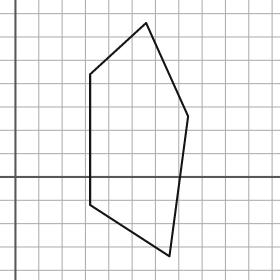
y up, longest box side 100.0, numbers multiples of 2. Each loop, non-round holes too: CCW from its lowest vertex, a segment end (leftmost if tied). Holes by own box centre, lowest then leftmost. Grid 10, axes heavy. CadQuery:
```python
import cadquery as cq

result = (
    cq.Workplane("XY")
    .moveTo(66.0, -34.0)
    .lineTo(74.0, 26.0)
    .lineTo(56.0, 66.0)
    .lineTo(32.0, 44.0)
    .lineTo(32.0, -12.0)
    .close()
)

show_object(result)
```